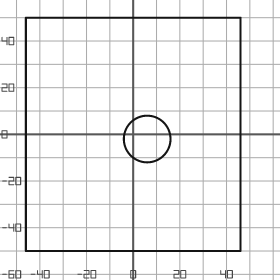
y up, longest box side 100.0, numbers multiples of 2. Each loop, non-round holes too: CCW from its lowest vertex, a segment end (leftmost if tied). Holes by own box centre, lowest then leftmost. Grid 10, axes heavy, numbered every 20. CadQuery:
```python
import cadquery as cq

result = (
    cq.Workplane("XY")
    .moveTo(-46.0, -50.0)
    .lineTo(46.0, -50.0)
    .lineTo(46.0, 50.0)
    .lineTo(-46.0, 50.0)
    .close()
    .moveTo(6.0, -2.0)
    .circle(10.0)
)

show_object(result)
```